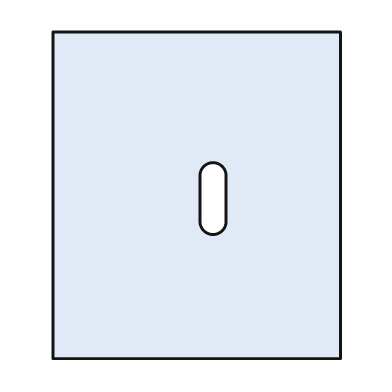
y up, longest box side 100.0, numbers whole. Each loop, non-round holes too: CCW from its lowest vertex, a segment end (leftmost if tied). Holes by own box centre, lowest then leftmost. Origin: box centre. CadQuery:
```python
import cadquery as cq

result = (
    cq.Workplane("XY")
    .moveTo(-44.0, -50.0)
    .lineTo(44.0, -50.0)
    .lineTo(44.0, 50.0)
    .lineTo(-44.0, 50.0)
    .close()
    .moveTo(1.0, -8.0)
    .threePointArc((5.0, -12.0), (9.0, -8.0))
    .lineTo(9.0, 6.0)
    .threePointArc((5.0, 10.0), (1.0, 6.0))
    .close()
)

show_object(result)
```